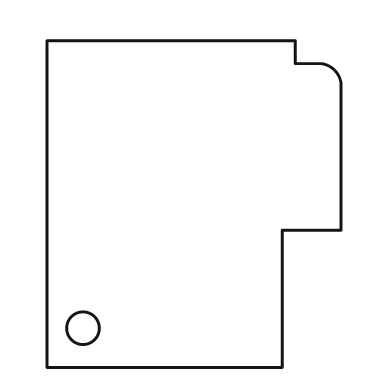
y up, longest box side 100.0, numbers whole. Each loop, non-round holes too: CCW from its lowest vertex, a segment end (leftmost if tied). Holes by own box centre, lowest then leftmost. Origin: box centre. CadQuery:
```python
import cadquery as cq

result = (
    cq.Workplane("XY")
    .moveTo(-45.0, -50.0)
    .lineTo(27.0, -50.0)
    .lineTo(27.0, -8.0)
    .lineTo(45.0, -8.0)
    .lineTo(45.0, 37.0)
    .threePointArc((43.0, 41.0), (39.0, 43.0))
    .lineTo(31.0, 43.0)
    .lineTo(31.0, 50.0)
    .lineTo(-45.0, 50.0)
    .close()
    .moveTo(-34.0, -38.0)
    .circle(5.0)
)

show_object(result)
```